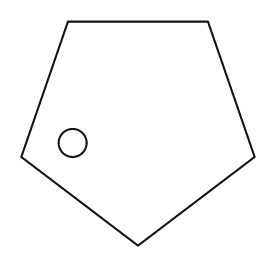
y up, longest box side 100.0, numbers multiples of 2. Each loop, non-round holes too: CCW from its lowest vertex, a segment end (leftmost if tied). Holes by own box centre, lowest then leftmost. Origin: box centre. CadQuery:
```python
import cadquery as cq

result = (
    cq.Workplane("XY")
    .moveTo(0.0, -48.0)
    .lineTo(50.0, -10.0)
    .lineTo(30.0, 48.0)
    .lineTo(-30.0, 48.0)
    .lineTo(-50.0, -10.0)
    .close()
    .moveTo(-28.0, -4.0)
    .circle(6.0)
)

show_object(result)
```